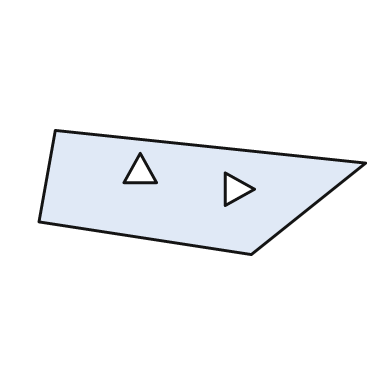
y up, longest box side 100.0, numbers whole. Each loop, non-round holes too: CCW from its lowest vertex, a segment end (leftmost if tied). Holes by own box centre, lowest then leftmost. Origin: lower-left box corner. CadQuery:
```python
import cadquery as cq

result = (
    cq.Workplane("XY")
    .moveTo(65.0, 0.0)
    .lineTo(100.0, 28.0)
    .lineTo(5.0, 38.0)
    .lineTo(0.0, 10.0)
    .close()
    .moveTo(57.0, 15.0)
    .lineTo(66.0, 20.0)
    .lineTo(57.0, 25.0)
    .close()
    .moveTo(26.0, 22.0)
    .lineTo(36.0, 22.0)
    .lineTo(31.0, 31.0)
    .close()
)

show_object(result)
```